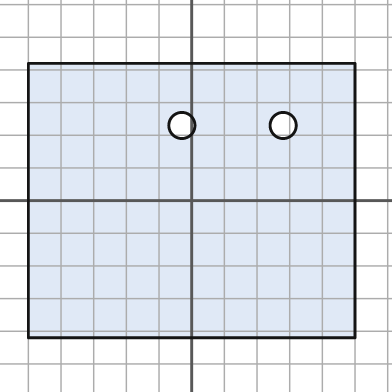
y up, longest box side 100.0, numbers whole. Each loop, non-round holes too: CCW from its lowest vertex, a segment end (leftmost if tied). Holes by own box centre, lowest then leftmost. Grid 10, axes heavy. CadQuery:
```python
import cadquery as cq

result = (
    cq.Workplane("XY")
    .moveTo(-50.0, -42.0)
    .lineTo(50.0, -42.0)
    .lineTo(50.0, 42.0)
    .lineTo(-50.0, 42.0)
    .close()
    .moveTo(-3.0, 23.0)
    .circle(4.0)
    .moveTo(28.0, 23.0)
    .circle(4.0)
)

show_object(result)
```